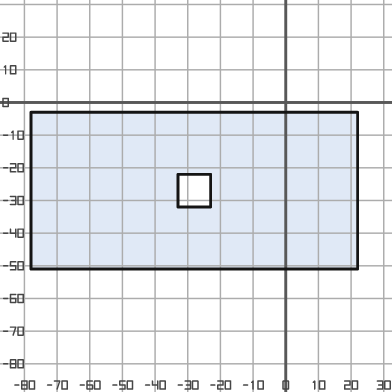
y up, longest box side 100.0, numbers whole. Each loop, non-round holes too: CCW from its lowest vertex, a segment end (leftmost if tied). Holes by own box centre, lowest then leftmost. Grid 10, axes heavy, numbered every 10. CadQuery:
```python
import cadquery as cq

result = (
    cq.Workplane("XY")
    .moveTo(-78.0, -51.0)
    .lineTo(22.0, -51.0)
    .lineTo(22.0, -3.0)
    .lineTo(-78.0, -3.0)
    .close()
    .moveTo(-33.0, -32.0)
    .lineTo(-23.0, -32.0)
    .lineTo(-23.0, -22.0)
    .lineTo(-33.0, -22.0)
    .close()
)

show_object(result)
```